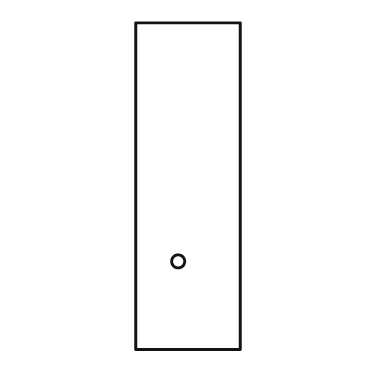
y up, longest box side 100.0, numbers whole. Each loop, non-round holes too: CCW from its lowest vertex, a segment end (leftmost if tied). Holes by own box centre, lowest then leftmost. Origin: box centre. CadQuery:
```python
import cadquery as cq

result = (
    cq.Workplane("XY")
    .moveTo(-16.0, -50.0)
    .lineTo(16.0, -50.0)
    .lineTo(16.0, 50.0)
    .lineTo(-16.0, 50.0)
    .close()
    .moveTo(-3.0, -23.0)
    .circle(2.0)
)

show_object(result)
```